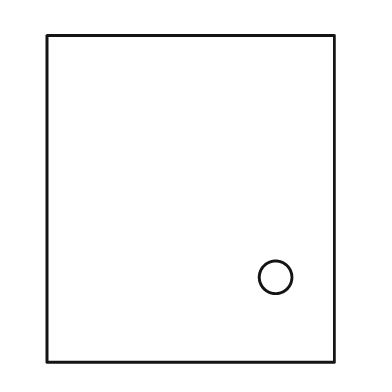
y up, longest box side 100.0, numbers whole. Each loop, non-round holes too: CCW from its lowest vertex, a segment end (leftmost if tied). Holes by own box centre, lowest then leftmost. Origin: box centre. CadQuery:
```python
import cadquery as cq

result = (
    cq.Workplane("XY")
    .moveTo(-44.0, -50.0)
    .lineTo(44.0, -50.0)
    .lineTo(44.0, 50.0)
    .lineTo(-44.0, 50.0)
    .close()
    .moveTo(26.0, -24.0)
    .circle(5.0)
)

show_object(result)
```